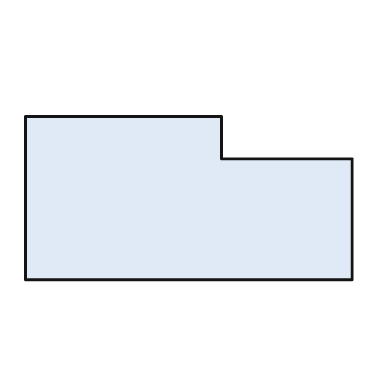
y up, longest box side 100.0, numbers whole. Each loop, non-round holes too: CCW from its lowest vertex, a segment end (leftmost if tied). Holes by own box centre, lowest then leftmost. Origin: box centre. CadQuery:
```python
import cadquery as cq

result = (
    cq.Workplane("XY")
    .moveTo(-50.0, -25.0)
    .lineTo(50.0, -25.0)
    .lineTo(50.0, 12.0)
    .lineTo(10.0, 12.0)
    .lineTo(10.0, 25.0)
    .lineTo(-50.0, 25.0)
    .close()
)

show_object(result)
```